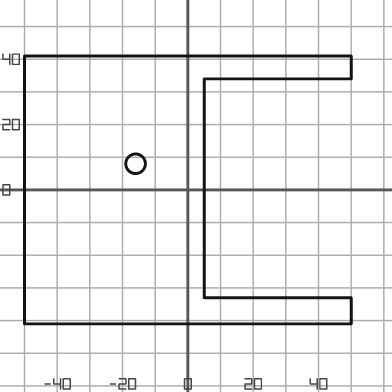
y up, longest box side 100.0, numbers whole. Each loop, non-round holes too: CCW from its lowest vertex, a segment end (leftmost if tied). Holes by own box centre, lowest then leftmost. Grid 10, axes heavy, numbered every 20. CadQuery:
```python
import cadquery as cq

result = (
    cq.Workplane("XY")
    .moveTo(-50.0, -41.0)
    .lineTo(50.0, -41.0)
    .lineTo(50.0, -33.0)
    .lineTo(5.0, -33.0)
    .lineTo(5.0, 34.0)
    .lineTo(50.0, 34.0)
    .lineTo(50.0, 41.0)
    .lineTo(-50.0, 41.0)
    .close()
    .moveTo(-16.0, 8.0)
    .circle(3.0)
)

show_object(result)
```